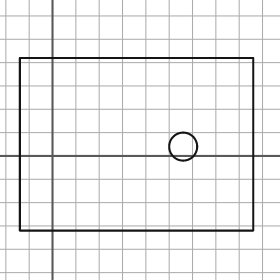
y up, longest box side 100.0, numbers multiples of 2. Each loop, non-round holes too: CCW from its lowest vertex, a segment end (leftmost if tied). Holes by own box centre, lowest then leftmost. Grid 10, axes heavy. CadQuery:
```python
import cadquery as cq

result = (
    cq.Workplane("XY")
    .moveTo(-14.0, -32.0)
    .lineTo(86.0, -32.0)
    .lineTo(86.0, 42.0)
    .lineTo(-14.0, 42.0)
    .close()
    .moveTo(56.0, 4.0)
    .circle(6.0)
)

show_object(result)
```